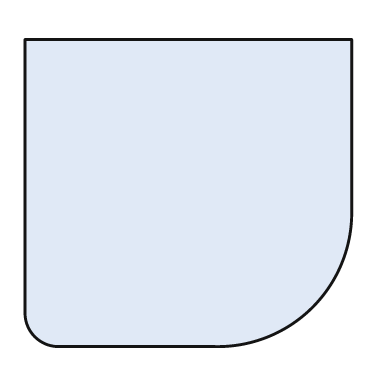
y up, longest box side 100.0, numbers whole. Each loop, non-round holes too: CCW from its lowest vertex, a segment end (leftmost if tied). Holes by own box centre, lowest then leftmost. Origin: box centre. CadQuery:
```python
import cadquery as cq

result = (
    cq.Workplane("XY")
    .moveTo(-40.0, -47.0)
    .lineTo(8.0, -47.0)
    .threePointArc((38.0, -35.0), (50.0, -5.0))
    .lineTo(50.0, 47.0)
    .lineTo(-50.0, 47.0)
    .lineTo(-50.0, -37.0)
    .threePointArc((-47.0, -44.0), (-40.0, -47.0))
    .close()
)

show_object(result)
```